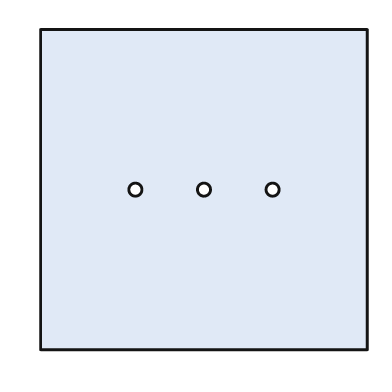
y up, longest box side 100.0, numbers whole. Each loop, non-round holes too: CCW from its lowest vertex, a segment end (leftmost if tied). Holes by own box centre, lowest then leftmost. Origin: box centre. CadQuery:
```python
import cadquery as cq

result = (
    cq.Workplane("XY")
    .moveTo(-50.0, -49.0)
    .lineTo(50.0, -49.0)
    .lineTo(50.0, 49.0)
    .lineTo(-50.0, 49.0)
    .close()
    .moveTo(-21.0, 0.0)
    .circle(2.0)
    .moveTo(0.0, 0.0)
    .circle(2.0)
    .moveTo(21.0, 0.0)
    .circle(2.0)
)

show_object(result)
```